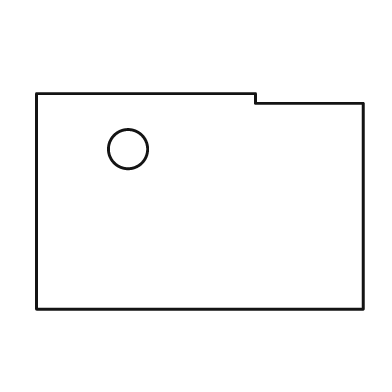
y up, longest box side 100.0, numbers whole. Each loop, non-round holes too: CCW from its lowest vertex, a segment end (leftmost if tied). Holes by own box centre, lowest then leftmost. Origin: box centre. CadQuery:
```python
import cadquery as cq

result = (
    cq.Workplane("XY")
    .moveTo(-50.0, -33.0)
    .lineTo(50.0, -33.0)
    .lineTo(50.0, 30.0)
    .lineTo(17.0, 30.0)
    .lineTo(17.0, 33.0)
    .lineTo(-50.0, 33.0)
    .close()
    .moveTo(-22.0, 16.0)
    .circle(6.0)
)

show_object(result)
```